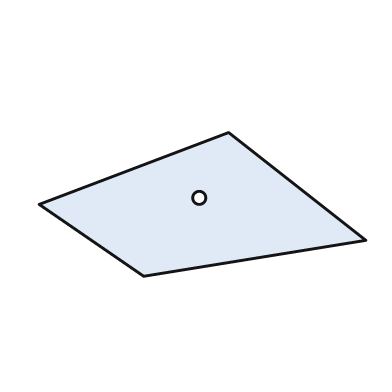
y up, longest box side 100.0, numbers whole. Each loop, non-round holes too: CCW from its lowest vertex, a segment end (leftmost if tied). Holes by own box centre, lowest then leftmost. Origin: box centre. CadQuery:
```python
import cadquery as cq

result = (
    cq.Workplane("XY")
    .moveTo(-18.0, -22.0)
    .lineTo(50.0, -11.0)
    .lineTo(8.0, 22.0)
    .lineTo(-50.0, 0.0)
    .close()
    .moveTo(-1.0, 2.0)
    .circle(2.0)
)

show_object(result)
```